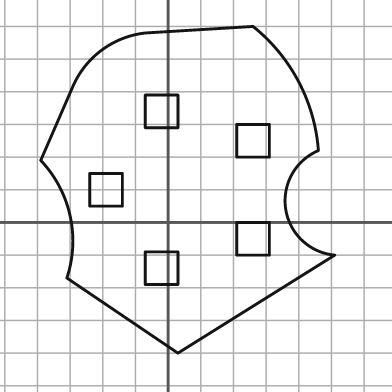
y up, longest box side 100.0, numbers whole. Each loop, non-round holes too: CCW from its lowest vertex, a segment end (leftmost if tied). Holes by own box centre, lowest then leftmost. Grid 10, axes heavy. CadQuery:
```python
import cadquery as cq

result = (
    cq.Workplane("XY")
    .moveTo(3.0, -40.0)
    .lineTo(51.0, -10.0)
    .threePointArc((36.0, 4.0), (46.0, 22.0))
    .threePointArc((40.0, 43.0), (26.0, 60.0))
    .lineTo(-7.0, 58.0)
    .threePointArc((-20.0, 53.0), (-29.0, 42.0))
    .lineTo(-39.0, 19.0)
    .threePointArc((-30.0, 2.0), (-31.0, -17.0))
    .close()
    .moveTo(-7.0, -19.0)
    .lineTo(3.0, -19.0)
    .lineTo(3.0, -9.0)
    .lineTo(-7.0, -9.0)
    .close()
    .moveTo(21.0, -10.0)
    .lineTo(31.0, -10.0)
    .lineTo(31.0, 0.0)
    .lineTo(21.0, 0.0)
    .close()
    .moveTo(-24.0, 5.0)
    .lineTo(-14.0, 5.0)
    .lineTo(-14.0, 15.0)
    .lineTo(-24.0, 15.0)
    .close()
    .moveTo(21.0, 20.0)
    .lineTo(31.0, 20.0)
    .lineTo(31.0, 30.0)
    .lineTo(21.0, 30.0)
    .close()
    .moveTo(-7.0, 29.0)
    .lineTo(3.0, 29.0)
    .lineTo(3.0, 39.0)
    .lineTo(-7.0, 39.0)
    .close()
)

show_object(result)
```